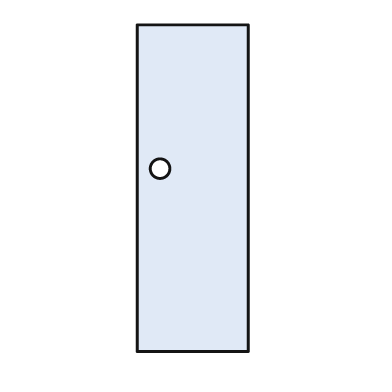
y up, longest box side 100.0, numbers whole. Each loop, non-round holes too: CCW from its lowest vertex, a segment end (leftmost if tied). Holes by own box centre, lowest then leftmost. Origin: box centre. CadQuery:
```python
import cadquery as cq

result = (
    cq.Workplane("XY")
    .moveTo(-17.0, -50.0)
    .lineTo(17.0, -50.0)
    .lineTo(17.0, 50.0)
    .lineTo(-17.0, 50.0)
    .close()
    .moveTo(-10.0, 6.0)
    .circle(3.0)
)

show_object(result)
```